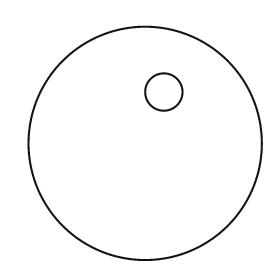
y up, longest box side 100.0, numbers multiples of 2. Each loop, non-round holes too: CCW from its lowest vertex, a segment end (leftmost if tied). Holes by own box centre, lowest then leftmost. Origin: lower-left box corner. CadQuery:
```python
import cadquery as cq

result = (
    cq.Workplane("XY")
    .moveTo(50.0, 50.0)
    .circle(50.0)
    .moveTo(58.0, 72.0)
    .circle(8.0)
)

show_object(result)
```